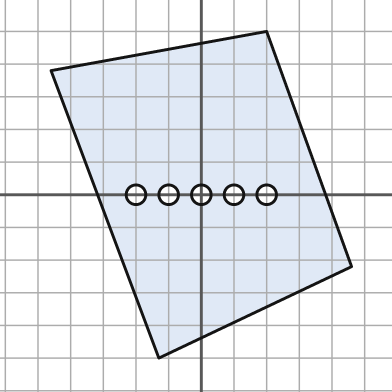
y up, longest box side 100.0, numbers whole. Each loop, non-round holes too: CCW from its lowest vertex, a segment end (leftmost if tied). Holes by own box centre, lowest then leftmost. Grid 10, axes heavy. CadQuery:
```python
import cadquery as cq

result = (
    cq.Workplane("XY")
    .moveTo(-13.0, -50.0)
    .lineTo(46.0, -22.0)
    .lineTo(20.0, 50.0)
    .lineTo(-46.0, 38.0)
    .close()
    .moveTo(-20.0, 0.0)
    .circle(3.0)
    .moveTo(-10.0, 0.0)
    .circle(3.0)
    .moveTo(0.0, 0.0)
    .circle(3.0)
    .moveTo(10.0, 0.0)
    .circle(3.0)
    .moveTo(20.0, 0.0)
    .circle(3.0)
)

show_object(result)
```